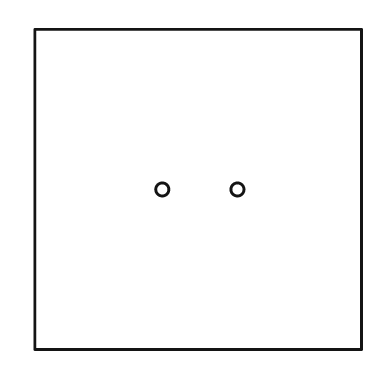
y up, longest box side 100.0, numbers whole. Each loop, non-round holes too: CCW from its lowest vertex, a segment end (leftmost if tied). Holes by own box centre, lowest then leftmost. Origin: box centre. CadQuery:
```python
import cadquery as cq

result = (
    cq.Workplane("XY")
    .moveTo(-50.0, -49.0)
    .lineTo(50.0, -49.0)
    .lineTo(50.0, 49.0)
    .lineTo(-50.0, 49.0)
    .close()
    .moveTo(-11.0, 0.0)
    .circle(2.0)
    .moveTo(12.0, 0.0)
    .circle(2.0)
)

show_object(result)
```